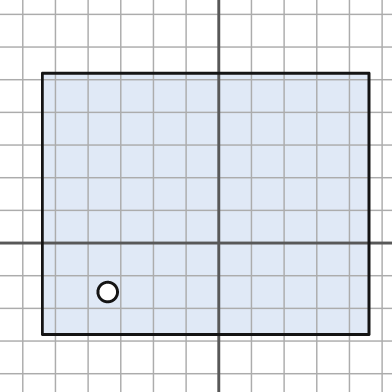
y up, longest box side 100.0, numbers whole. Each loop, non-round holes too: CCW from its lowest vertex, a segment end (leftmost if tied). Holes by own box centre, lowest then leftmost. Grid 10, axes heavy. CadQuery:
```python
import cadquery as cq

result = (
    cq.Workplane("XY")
    .moveTo(-54.0, -28.0)
    .lineTo(46.0, -28.0)
    .lineTo(46.0, 52.0)
    .lineTo(-54.0, 52.0)
    .close()
    .moveTo(-34.0, -15.0)
    .circle(3.0)
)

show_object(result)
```